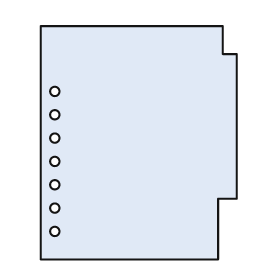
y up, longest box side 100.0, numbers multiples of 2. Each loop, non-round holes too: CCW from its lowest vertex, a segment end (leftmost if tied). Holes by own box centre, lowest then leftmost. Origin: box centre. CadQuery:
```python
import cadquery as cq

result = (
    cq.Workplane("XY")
    .moveTo(-42.0, -50.0)
    .lineTo(34.0, -50.0)
    .lineTo(34.0, -24.0)
    .lineTo(42.0, -24.0)
    .lineTo(42.0, 38.0)
    .lineTo(36.0, 38.0)
    .lineTo(36.0, 50.0)
    .lineTo(-42.0, 50.0)
    .close()
    .moveTo(-36.0, -38.0)
    .circle(2.0)
    .moveTo(-36.0, -28.0)
    .circle(2.0)
    .moveTo(-36.0, -18.0)
    .circle(2.0)
    .moveTo(-36.0, -8.0)
    .circle(2.0)
    .moveTo(-36.0, 2.0)
    .circle(2.0)
    .moveTo(-36.0, 12.0)
    .circle(2.0)
    .moveTo(-36.0, 22.0)
    .circle(2.0)
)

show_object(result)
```